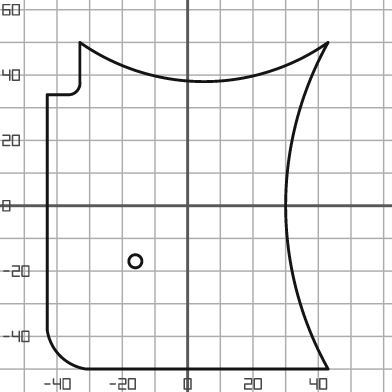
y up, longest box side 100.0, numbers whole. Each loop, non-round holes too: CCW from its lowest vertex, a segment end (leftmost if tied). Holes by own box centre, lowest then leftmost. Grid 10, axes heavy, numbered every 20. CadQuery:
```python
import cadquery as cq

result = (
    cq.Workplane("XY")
    .moveTo(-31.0, -50.0)
    .lineTo(43.0, -50.0)
    .threePointArc((30.0, 0.0), (43.0, 50.0))
    .threePointArc((5.0, 38.0), (-33.0, 50.0))
    .lineTo(-33.0, 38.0)
    .threePointArc((-34.0, 35.0), (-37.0, 34.0))
    .lineTo(-43.0, 34.0)
    .lineTo(-43.0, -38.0)
    .threePointArc((-39.0, -46.0), (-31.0, -50.0))
    .close()
    .moveTo(-16.0, -17.0)
    .circle(2.0)
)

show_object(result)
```